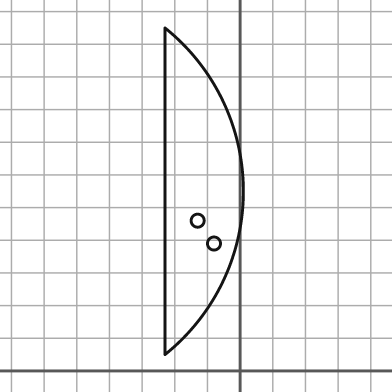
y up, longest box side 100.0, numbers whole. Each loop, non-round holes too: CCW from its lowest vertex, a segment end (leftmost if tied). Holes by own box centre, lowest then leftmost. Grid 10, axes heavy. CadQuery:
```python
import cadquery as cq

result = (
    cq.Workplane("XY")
    .moveTo(-23.0, 5.0)
    .threePointArc((1.0, 55.0), (-23.0, 105.0))
    .close()
    .moveTo(-8.0, 39.0)
    .circle(2.0)
    .moveTo(-13.0, 46.0)
    .circle(2.0)
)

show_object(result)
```